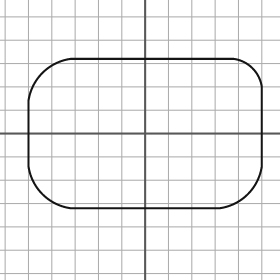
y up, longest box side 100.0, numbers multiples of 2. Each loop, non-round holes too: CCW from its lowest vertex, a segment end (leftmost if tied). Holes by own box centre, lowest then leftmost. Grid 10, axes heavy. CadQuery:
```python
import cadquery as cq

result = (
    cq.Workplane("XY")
    .moveTo(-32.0, -32.0)
    .lineTo(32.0, -32.0)
    .threePointArc((44.0, -26.0), (50.0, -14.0))
    .lineTo(50.0, 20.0)
    .threePointArc((46.0, 28.0), (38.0, 32.0))
    .lineTo(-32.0, 32.0)
    .threePointArc((-44.0, 26.0), (-50.0, 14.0))
    .lineTo(-50.0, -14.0)
    .threePointArc((-44.0, -26.0), (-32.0, -32.0))
    .close()
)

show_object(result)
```